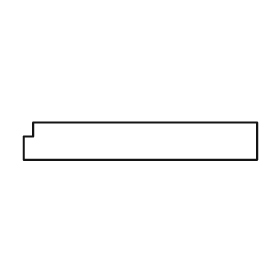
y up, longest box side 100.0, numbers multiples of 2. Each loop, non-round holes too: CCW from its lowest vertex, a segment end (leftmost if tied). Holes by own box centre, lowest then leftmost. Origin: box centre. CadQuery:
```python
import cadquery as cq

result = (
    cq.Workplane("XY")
    .moveTo(-50.0, -8.0)
    .lineTo(50.0, -8.0)
    .lineTo(50.0, 8.0)
    .lineTo(-46.0, 8.0)
    .lineTo(-46.0, 2.0)
    .lineTo(-50.0, 2.0)
    .close()
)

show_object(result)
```